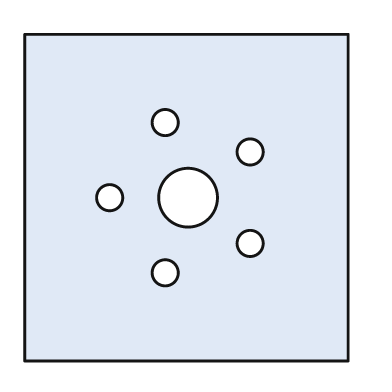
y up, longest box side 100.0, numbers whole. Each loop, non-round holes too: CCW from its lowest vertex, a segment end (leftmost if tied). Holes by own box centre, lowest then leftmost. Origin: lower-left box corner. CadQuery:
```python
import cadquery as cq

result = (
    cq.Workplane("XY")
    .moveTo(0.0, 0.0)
    .lineTo(99.0, 0.0)
    .lineTo(99.0, 100.0)
    .lineTo(0.0, 100.0)
    .close()
    .moveTo(43.0, 27.0)
    .circle(4.0)
    .moveTo(69.0, 36.0)
    .circle(4.0)
    .moveTo(26.0, 50.0)
    .circle(4.0)
    .moveTo(50.0, 50.0)
    .circle(9.0)
    .moveTo(69.0, 64.0)
    .circle(4.0)
    .moveTo(43.0, 73.0)
    .circle(4.0)
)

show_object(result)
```